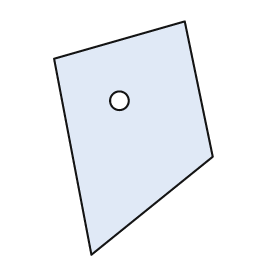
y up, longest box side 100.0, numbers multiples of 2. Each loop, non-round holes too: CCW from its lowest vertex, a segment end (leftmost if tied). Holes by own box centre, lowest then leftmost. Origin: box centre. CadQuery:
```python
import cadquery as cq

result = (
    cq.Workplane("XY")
    .moveTo(-18.0, -50.0)
    .lineTo(34.0, -8.0)
    .lineTo(22.0, 50.0)
    .lineTo(-34.0, 34.0)
    .close()
    .moveTo(-6.0, 16.0)
    .circle(4.0)
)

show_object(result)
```